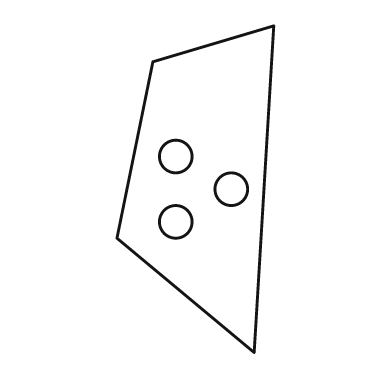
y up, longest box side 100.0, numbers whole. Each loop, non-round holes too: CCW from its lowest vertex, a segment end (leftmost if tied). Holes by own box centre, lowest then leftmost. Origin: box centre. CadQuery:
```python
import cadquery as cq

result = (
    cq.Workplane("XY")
    .moveTo(18.0, -50.0)
    .lineTo(24.0, 50.0)
    .lineTo(-13.0, 39.0)
    .lineTo(-24.0, -15.0)
    .close()
    .moveTo(-6.0, -10.0)
    .circle(5.0)
    .moveTo(11.0, 0.0)
    .circle(5.0)
    .moveTo(-6.0, 10.0)
    .circle(5.0)
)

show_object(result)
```